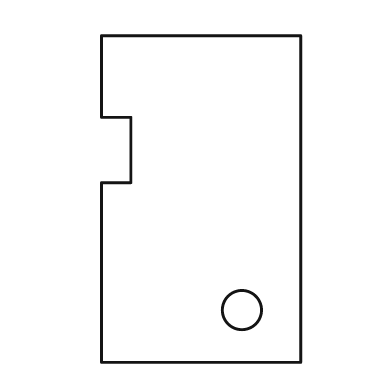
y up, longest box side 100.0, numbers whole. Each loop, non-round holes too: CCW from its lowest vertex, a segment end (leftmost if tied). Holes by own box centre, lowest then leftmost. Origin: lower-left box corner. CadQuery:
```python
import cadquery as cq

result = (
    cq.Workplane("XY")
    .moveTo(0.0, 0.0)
    .lineTo(61.0, 0.0)
    .lineTo(61.0, 100.0)
    .lineTo(0.0, 100.0)
    .lineTo(0.0, 75.0)
    .lineTo(9.0, 75.0)
    .lineTo(9.0, 55.0)
    .lineTo(0.0, 55.0)
    .close()
    .moveTo(43.0, 16.0)
    .circle(6.0)
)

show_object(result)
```